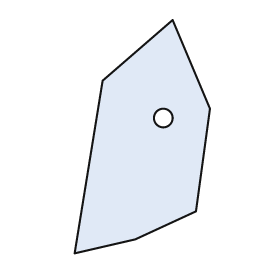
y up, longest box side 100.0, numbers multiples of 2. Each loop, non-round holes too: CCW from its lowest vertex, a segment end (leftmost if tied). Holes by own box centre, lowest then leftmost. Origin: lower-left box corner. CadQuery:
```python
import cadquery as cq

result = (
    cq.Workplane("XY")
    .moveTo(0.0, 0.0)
    .lineTo(26.0, 6.0)
    .lineTo(52.0, 18.0)
    .lineTo(58.0, 62.0)
    .lineTo(42.0, 100.0)
    .lineTo(12.0, 74.0)
    .close()
    .moveTo(38.0, 58.0)
    .circle(4.0)
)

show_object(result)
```